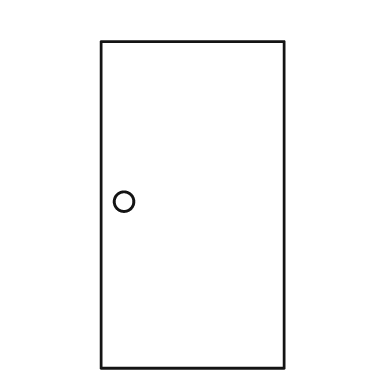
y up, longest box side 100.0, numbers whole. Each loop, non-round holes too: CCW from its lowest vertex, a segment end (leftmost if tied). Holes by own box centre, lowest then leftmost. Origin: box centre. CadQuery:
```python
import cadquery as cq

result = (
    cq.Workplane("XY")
    .moveTo(-28.0, -50.0)
    .lineTo(28.0, -50.0)
    .lineTo(28.0, 50.0)
    .lineTo(-28.0, 50.0)
    .close()
    .moveTo(-21.0, 1.0)
    .circle(3.0)
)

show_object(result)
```